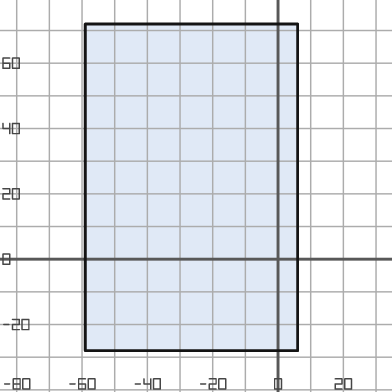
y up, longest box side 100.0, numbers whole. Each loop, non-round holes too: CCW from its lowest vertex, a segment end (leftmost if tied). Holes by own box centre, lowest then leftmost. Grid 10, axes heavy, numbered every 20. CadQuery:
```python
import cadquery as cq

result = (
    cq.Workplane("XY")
    .moveTo(-59.0, -28.0)
    .lineTo(6.0, -28.0)
    .lineTo(6.0, 72.0)
    .lineTo(-59.0, 72.0)
    .close()
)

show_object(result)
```